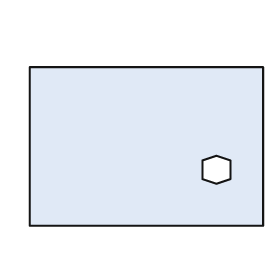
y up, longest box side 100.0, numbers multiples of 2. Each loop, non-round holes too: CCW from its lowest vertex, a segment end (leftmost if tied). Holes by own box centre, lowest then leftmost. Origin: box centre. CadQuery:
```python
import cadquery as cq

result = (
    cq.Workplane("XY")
    .moveTo(-50.0, -34.0)
    .lineTo(50.0, -34.0)
    .lineTo(50.0, 34.0)
    .lineTo(-50.0, 34.0)
    .close()
    .moveTo(30.0, -16.0)
    .lineTo(36.0, -14.0)
    .lineTo(36.0, -6.0)
    .lineTo(30.0, -4.0)
    .lineTo(24.0, -6.0)
    .lineTo(24.0, -14.0)
    .close()
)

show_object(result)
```